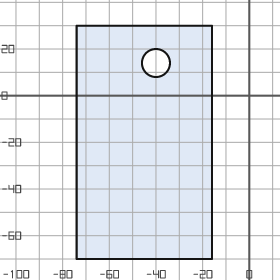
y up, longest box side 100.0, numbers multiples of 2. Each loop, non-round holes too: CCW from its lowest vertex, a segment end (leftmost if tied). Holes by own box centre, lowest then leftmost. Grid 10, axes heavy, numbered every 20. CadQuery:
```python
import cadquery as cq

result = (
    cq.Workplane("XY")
    .moveTo(-74.0, -70.0)
    .lineTo(-16.0, -70.0)
    .lineTo(-16.0, 30.0)
    .lineTo(-74.0, 30.0)
    .close()
    .moveTo(-40.0, 14.0)
    .circle(6.0)
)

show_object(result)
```